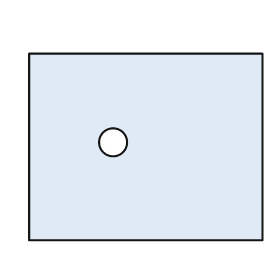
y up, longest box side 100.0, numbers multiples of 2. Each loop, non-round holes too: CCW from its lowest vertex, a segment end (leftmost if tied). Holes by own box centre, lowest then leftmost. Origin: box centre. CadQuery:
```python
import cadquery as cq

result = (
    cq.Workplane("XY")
    .moveTo(-50.0, -40.0)
    .lineTo(50.0, -40.0)
    .lineTo(50.0, 40.0)
    .lineTo(-50.0, 40.0)
    .close()
    .moveTo(-14.0, 2.0)
    .circle(6.0)
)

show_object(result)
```